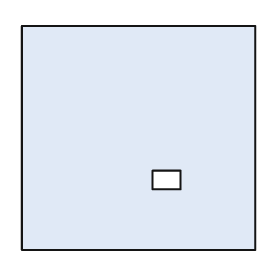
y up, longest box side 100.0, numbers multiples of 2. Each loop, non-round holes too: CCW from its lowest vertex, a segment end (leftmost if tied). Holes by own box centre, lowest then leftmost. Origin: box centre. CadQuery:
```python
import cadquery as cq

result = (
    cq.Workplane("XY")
    .moveTo(-50.0, -48.0)
    .lineTo(50.0, -48.0)
    .lineTo(50.0, 48.0)
    .lineTo(-50.0, 48.0)
    .close()
    .moveTo(6.0, -22.0)
    .lineTo(18.0, -22.0)
    .lineTo(18.0, -14.0)
    .lineTo(6.0, -14.0)
    .close()
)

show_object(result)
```